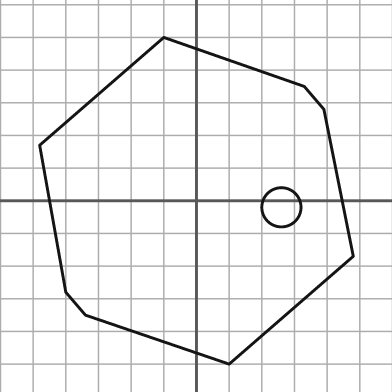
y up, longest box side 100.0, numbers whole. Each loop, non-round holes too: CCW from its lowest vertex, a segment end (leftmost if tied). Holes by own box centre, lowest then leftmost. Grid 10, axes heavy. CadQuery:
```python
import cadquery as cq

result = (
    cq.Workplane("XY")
    .moveTo(10.0, -50.0)
    .lineTo(48.0, -17.0)
    .lineTo(39.0, 28.0)
    .lineTo(33.0, 35.0)
    .lineTo(-10.0, 50.0)
    .lineTo(-48.0, 17.0)
    .lineTo(-40.0, -28.0)
    .lineTo(-34.0, -35.0)
    .close()
    .moveTo(26.0, -2.0)
    .circle(6.0)
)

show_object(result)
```